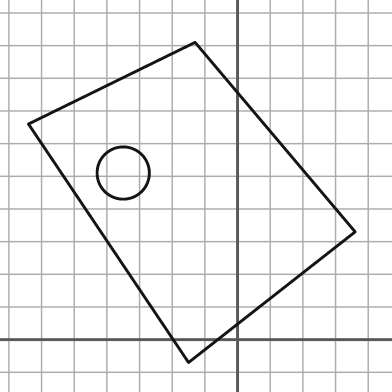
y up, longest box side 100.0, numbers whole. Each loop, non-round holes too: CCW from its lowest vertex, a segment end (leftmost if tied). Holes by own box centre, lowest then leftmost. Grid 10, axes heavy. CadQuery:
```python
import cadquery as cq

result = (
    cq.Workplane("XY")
    .moveTo(-15.0, -7.0)
    .lineTo(36.0, 33.0)
    .lineTo(-13.0, 91.0)
    .lineTo(-64.0, 66.0)
    .close()
    .moveTo(-35.0, 51.0)
    .circle(8.0)
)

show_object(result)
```